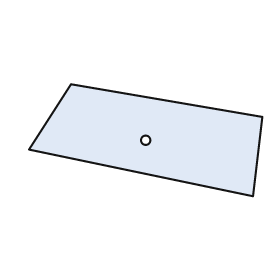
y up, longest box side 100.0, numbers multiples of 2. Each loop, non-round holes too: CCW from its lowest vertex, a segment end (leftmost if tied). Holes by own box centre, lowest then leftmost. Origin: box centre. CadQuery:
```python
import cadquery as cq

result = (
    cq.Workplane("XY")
    .moveTo(46.0, -24.0)
    .lineTo(50.0, 10.0)
    .lineTo(-32.0, 24.0)
    .lineTo(-50.0, -4.0)
    .close()
    .moveTo(0.0, 0.0)
    .circle(2.0)
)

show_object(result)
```